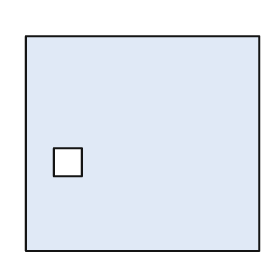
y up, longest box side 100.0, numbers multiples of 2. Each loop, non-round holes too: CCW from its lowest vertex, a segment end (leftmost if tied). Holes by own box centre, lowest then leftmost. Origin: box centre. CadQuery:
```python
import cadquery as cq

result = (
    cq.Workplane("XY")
    .moveTo(-50.0, -46.0)
    .lineTo(50.0, -46.0)
    .lineTo(50.0, 46.0)
    .lineTo(-50.0, 46.0)
    .close()
    .moveTo(-38.0, -14.0)
    .lineTo(-26.0, -14.0)
    .lineTo(-26.0, -2.0)
    .lineTo(-38.0, -2.0)
    .close()
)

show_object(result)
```